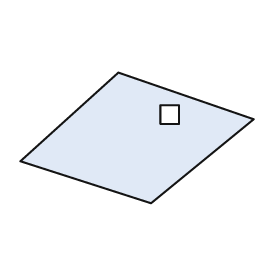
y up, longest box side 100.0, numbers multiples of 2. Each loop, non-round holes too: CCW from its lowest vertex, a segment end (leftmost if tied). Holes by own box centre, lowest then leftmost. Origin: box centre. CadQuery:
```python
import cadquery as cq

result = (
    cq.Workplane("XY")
    .moveTo(6.0, -28.0)
    .lineTo(50.0, 8.0)
    .lineTo(-8.0, 28.0)
    .lineTo(-50.0, -10.0)
    .close()
    .moveTo(10.0, 6.0)
    .lineTo(18.0, 6.0)
    .lineTo(18.0, 14.0)
    .lineTo(10.0, 14.0)
    .close()
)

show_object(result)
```